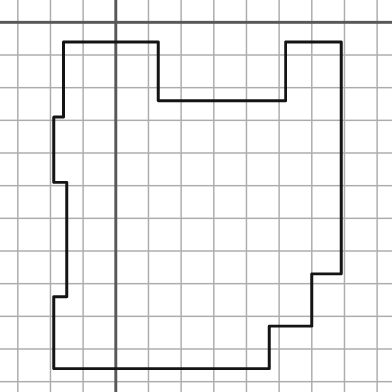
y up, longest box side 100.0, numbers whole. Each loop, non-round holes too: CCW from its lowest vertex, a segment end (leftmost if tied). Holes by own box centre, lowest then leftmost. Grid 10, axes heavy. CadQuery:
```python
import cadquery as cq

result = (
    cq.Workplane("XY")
    .moveTo(-19.0, -106.0)
    .lineTo(47.0, -106.0)
    .lineTo(47.0, -93.0)
    .lineTo(60.0, -93.0)
    .lineTo(60.0, -77.0)
    .lineTo(69.0, -77.0)
    .lineTo(69.0, -6.0)
    .lineTo(52.0, -6.0)
    .lineTo(52.0, -24.0)
    .lineTo(13.0, -24.0)
    .lineTo(13.0, -6.0)
    .lineTo(-16.0, -6.0)
    .lineTo(-16.0, -29.0)
    .lineTo(-19.0, -29.0)
    .lineTo(-19.0, -49.0)
    .lineTo(-15.0, -49.0)
    .lineTo(-15.0, -84.0)
    .lineTo(-19.0, -84.0)
    .close()
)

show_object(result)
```